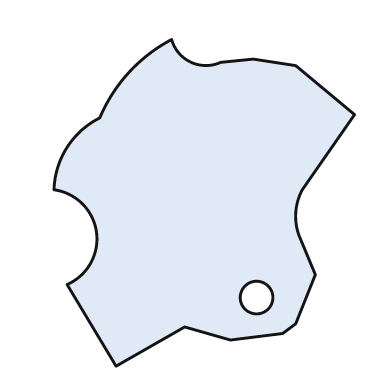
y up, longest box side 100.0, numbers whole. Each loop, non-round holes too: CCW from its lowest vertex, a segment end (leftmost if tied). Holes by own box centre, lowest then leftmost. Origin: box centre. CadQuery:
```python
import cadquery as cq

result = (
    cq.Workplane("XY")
    .moveTo(-27.0, -50.0)
    .lineTo(-6.0, -38.0)
    .lineTo(8.0, -42.0)
    .lineTo(24.0, -40.0)
    .lineTo(28.0, -37.0)
    .lineTo(34.0, -22.0)
    .lineTo(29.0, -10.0)
    .threePointArc((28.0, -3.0), (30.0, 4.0))
    .lineTo(46.0, 27.0)
    .lineTo(28.0, 42.0)
    .lineTo(15.0, 44.0)
    .lineTo(5.0, 43.0)
    .threePointArc((-4.0, 43.0), (-10.0, 50.0))
    .threePointArc((-23.0, 40.0), (-32.0, 26.0))
    .threePointArc((-42.0, 17.0), (-46.0, 4.0))
    .threePointArc((-33.0, -9.0), (-42.0, -25.0))
    .close()
    .moveTo(16.0, -29.0)
    .circle(5.0)
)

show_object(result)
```